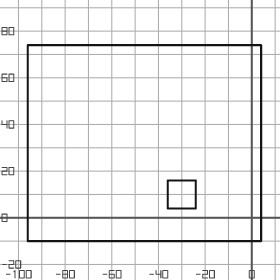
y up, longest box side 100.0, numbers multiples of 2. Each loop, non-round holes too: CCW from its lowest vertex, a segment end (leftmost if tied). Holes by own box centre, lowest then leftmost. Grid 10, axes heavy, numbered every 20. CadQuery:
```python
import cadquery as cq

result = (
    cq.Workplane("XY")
    .moveTo(-96.0, -10.0)
    .lineTo(4.0, -10.0)
    .lineTo(4.0, 74.0)
    .lineTo(-96.0, 74.0)
    .close()
    .moveTo(-36.0, 4.0)
    .lineTo(-24.0, 4.0)
    .lineTo(-24.0, 16.0)
    .lineTo(-36.0, 16.0)
    .close()
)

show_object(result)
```